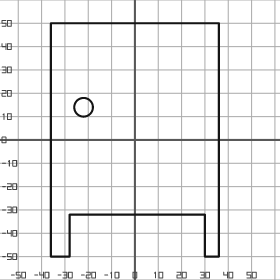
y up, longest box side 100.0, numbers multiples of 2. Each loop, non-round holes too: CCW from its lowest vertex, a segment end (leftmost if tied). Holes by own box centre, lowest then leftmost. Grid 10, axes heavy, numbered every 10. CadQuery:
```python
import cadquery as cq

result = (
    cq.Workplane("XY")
    .moveTo(-36.0, -50.0)
    .lineTo(-28.0, -50.0)
    .lineTo(-28.0, -32.0)
    .lineTo(30.0, -32.0)
    .lineTo(30.0, -50.0)
    .lineTo(36.0, -50.0)
    .lineTo(36.0, 50.0)
    .lineTo(-36.0, 50.0)
    .close()
    .moveTo(-22.0, 14.0)
    .circle(4.0)
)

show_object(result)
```